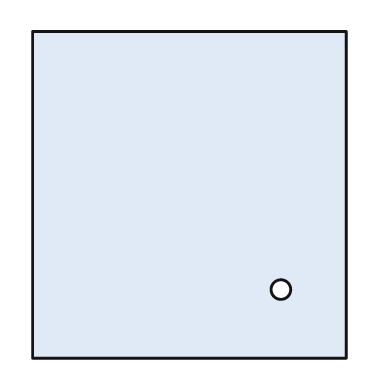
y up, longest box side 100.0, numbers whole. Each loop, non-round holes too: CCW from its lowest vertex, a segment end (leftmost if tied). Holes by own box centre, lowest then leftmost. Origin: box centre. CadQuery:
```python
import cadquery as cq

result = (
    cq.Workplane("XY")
    .moveTo(-48.0, -50.0)
    .lineTo(48.0, -50.0)
    .lineTo(48.0, 50.0)
    .lineTo(-48.0, 50.0)
    .close()
    .moveTo(28.0, -29.0)
    .circle(3.0)
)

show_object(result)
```